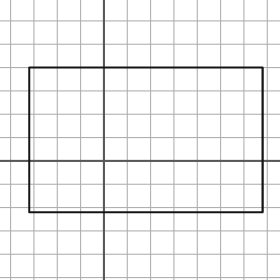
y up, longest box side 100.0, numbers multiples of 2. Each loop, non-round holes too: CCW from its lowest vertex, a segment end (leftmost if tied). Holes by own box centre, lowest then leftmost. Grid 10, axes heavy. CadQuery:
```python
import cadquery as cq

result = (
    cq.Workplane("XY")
    .moveTo(-32.0, -22.0)
    .lineTo(68.0, -22.0)
    .lineTo(68.0, 40.0)
    .lineTo(-32.0, 40.0)
    .close()
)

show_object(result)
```